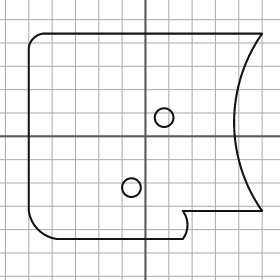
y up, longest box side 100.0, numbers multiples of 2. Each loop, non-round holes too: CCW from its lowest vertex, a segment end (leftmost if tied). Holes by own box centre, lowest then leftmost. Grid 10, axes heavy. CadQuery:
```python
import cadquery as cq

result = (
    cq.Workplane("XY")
    .moveTo(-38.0, -44.0)
    .lineTo(16.0, -44.0)
    .threePointArc((18.0, -38.0), (16.0, -32.0))
    .lineTo(50.0, -32.0)
    .threePointArc((38.0, 6.0), (50.0, 44.0))
    .lineTo(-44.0, 44.0)
    .threePointArc((-48.0, 42.0), (-50.0, 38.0))
    .lineTo(-50.0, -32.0)
    .threePointArc((-46.0, -40.0), (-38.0, -44.0))
    .close()
    .moveTo(-6.0, -22.0)
    .circle(4.0)
    .moveTo(8.0, 8.0)
    .circle(4.0)
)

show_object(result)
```